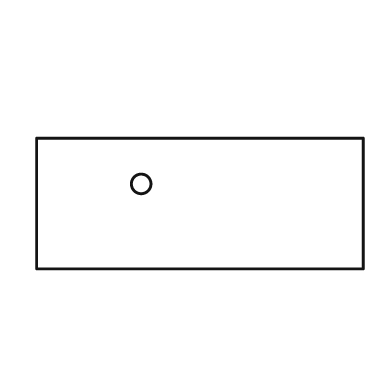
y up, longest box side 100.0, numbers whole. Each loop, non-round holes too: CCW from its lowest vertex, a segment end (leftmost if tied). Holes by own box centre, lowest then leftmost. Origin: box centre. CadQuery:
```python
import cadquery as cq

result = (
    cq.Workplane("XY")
    .moveTo(-50.0, -20.0)
    .lineTo(50.0, -20.0)
    .lineTo(50.0, 20.0)
    .lineTo(-50.0, 20.0)
    .close()
    .moveTo(-18.0, 6.0)
    .circle(3.0)
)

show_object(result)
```